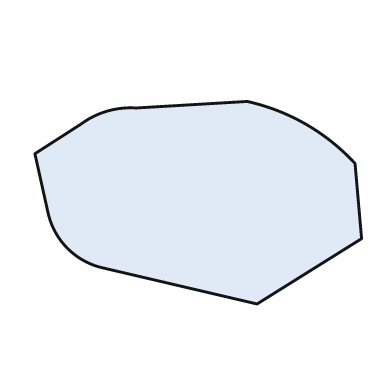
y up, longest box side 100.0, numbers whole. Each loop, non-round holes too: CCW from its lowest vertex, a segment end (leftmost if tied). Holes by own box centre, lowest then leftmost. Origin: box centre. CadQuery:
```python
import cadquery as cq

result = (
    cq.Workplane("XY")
    .moveTo(18.0, -31.0)
    .lineTo(50.0, -11.0)
    .lineTo(48.0, 12.0)
    .threePointArc((33.0, 24.0), (15.0, 31.0))
    .lineTo(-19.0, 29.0)
    .threePointArc((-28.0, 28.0), (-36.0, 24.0))
    .lineTo(-50.0, 15.0)
    .lineTo(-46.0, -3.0)
    .threePointArc((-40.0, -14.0), (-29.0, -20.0))
    .close()
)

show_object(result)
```